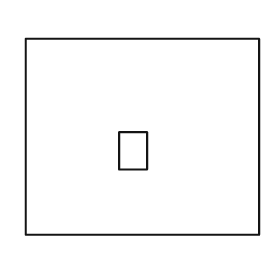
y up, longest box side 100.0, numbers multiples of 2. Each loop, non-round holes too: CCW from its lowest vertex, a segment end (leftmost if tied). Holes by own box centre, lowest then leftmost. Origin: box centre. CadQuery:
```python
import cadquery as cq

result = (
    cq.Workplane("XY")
    .moveTo(-50.0, -42.0)
    .lineTo(50.0, -42.0)
    .lineTo(50.0, 42.0)
    .lineTo(-50.0, 42.0)
    .close()
    .moveTo(-10.0, -14.0)
    .lineTo(2.0, -14.0)
    .lineTo(2.0, 2.0)
    .lineTo(-10.0, 2.0)
    .close()
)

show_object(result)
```